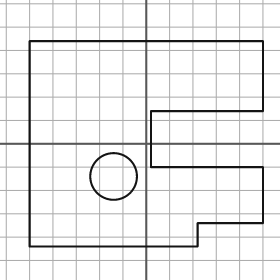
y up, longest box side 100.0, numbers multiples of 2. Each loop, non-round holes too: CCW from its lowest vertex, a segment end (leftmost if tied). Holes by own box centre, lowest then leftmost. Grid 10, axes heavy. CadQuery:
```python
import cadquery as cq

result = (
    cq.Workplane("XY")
    .moveTo(-50.0, -44.0)
    .lineTo(22.0, -44.0)
    .lineTo(22.0, -34.0)
    .lineTo(50.0, -34.0)
    .lineTo(50.0, -10.0)
    .lineTo(2.0, -10.0)
    .lineTo(2.0, 14.0)
    .lineTo(50.0, 14.0)
    .lineTo(50.0, 44.0)
    .lineTo(-50.0, 44.0)
    .close()
    .moveTo(-14.0, -14.0)
    .circle(10.0)
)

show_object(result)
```